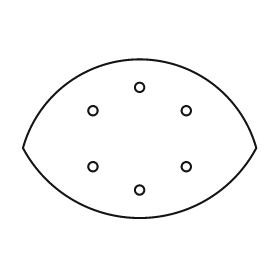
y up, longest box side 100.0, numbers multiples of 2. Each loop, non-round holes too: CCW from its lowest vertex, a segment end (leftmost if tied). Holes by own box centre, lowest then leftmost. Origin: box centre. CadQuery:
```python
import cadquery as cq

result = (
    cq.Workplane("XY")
    .moveTo(-50.0, -4.0)
    .threePointArc((0.0, -34.0), (50.0, -4.0))
    .threePointArc((0.0, 34.0), (-50.0, -4.0))
    .close()
    .moveTo(0.0, -22.0)
    .circle(2.0)
    .moveTo(-20.0, -12.0)
    .circle(2.0)
    .moveTo(20.0, -12.0)
    .circle(2.0)
    .moveTo(-20.0, 12.0)
    .circle(2.0)
    .moveTo(20.0, 12.0)
    .circle(2.0)
    .moveTo(0.0, 22.0)
    .circle(2.0)
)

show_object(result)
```